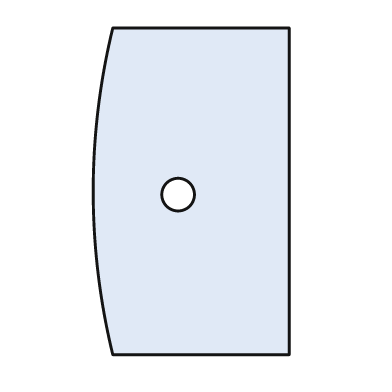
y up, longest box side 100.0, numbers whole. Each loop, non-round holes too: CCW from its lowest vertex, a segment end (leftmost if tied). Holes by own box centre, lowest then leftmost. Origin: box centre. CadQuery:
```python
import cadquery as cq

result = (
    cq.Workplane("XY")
    .moveTo(-24.0, -50.0)
    .lineTo(30.0, -50.0)
    .lineTo(30.0, 50.0)
    .lineTo(-24.0, 50.0)
    .threePointArc((-30.0, 0.0), (-24.0, -50.0))
    .close()
    .moveTo(-4.0, -1.0)
    .circle(5.0)
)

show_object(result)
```